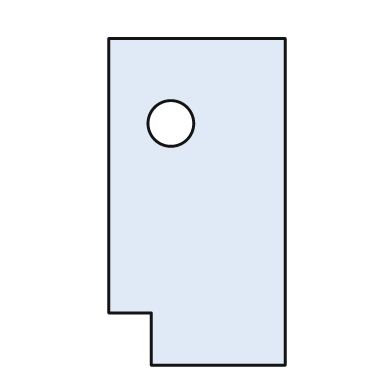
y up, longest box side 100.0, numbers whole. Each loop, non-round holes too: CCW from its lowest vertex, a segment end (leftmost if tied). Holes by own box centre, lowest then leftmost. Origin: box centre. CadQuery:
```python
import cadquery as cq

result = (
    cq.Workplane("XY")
    .moveTo(-14.0, -50.0)
    .lineTo(27.0, -50.0)
    .lineTo(27.0, 50.0)
    .lineTo(-27.0, 50.0)
    .lineTo(-27.0, -34.0)
    .lineTo(-14.0, -34.0)
    .close()
    .moveTo(-8.0, 24.0)
    .circle(7.0)
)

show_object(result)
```